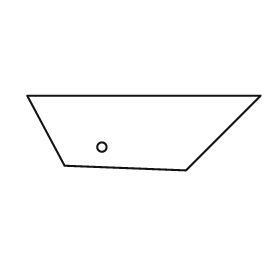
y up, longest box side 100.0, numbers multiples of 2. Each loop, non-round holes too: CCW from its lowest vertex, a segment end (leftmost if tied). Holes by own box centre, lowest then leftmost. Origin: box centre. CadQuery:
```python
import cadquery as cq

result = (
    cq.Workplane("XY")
    .moveTo(18.0, -16.0)
    .lineTo(50.0, 16.0)
    .lineTo(-50.0, 16.0)
    .lineTo(-34.0, -14.0)
    .close()
    .moveTo(-18.0, -6.0)
    .circle(2.0)
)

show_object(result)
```